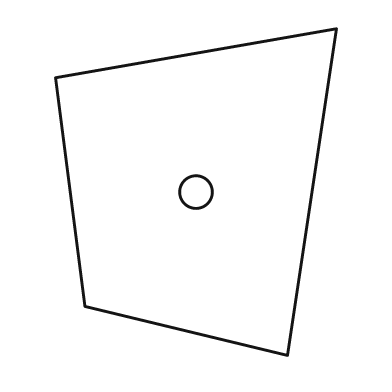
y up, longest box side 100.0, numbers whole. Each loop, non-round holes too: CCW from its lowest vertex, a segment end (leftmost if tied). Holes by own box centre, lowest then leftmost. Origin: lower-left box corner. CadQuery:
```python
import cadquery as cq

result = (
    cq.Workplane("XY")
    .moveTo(71.0, 0.0)
    .lineTo(86.0, 100.0)
    .lineTo(0.0, 85.0)
    .lineTo(9.0, 15.0)
    .close()
    .moveTo(43.0, 50.0)
    .circle(5.0)
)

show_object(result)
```